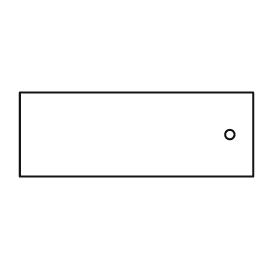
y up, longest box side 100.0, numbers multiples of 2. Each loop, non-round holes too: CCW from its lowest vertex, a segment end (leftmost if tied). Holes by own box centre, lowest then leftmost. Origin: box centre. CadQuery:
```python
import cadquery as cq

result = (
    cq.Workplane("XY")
    .moveTo(-50.0, -18.0)
    .lineTo(50.0, -18.0)
    .lineTo(50.0, 18.0)
    .lineTo(-50.0, 18.0)
    .close()
    .moveTo(40.0, 0.0)
    .circle(2.0)
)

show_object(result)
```